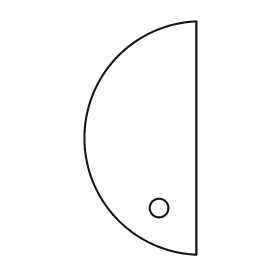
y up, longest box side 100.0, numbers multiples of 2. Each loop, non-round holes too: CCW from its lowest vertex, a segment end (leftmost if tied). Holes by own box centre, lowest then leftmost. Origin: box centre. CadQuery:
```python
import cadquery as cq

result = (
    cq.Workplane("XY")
    .moveTo(24.0, -50.0)
    .lineTo(24.0, 50.0)
    .threePointArc((-24.0, 0.0), (24.0, -50.0))
    .close()
    .moveTo(8.0, -30.0)
    .circle(4.0)
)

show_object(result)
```